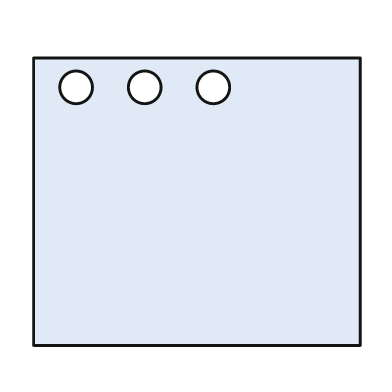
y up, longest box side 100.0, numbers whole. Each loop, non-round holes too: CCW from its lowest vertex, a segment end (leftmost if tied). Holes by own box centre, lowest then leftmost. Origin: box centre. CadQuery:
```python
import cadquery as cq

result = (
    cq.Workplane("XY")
    .moveTo(-50.0, -44.0)
    .lineTo(50.0, -44.0)
    .lineTo(50.0, 44.0)
    .lineTo(-50.0, 44.0)
    .close()
    .moveTo(-37.0, 35.0)
    .circle(5.0)
    .moveTo(-16.0, 35.0)
    .circle(5.0)
    .moveTo(5.0, 35.0)
    .circle(5.0)
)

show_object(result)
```